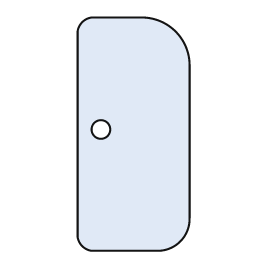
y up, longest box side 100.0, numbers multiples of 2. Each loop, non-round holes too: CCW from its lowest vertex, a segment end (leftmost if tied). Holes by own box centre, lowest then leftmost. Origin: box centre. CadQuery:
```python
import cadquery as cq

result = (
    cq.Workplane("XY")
    .moveTo(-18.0, -50.0)
    .lineTo(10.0, -50.0)
    .threePointArc((20.0, -46.0), (24.0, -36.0))
    .lineTo(24.0, 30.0)
    .threePointArc((18.0, 44.0), (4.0, 50.0))
    .lineTo(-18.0, 50.0)
    .threePointArc((-22.0, 48.0), (-24.0, 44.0))
    .lineTo(-24.0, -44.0)
    .threePointArc((-22.0, -48.0), (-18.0, -50.0))
    .close()
    .moveTo(-14.0, 2.0)
    .circle(4.0)
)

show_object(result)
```